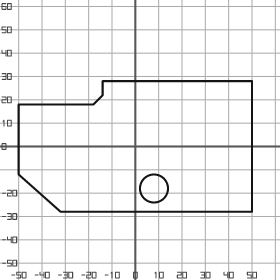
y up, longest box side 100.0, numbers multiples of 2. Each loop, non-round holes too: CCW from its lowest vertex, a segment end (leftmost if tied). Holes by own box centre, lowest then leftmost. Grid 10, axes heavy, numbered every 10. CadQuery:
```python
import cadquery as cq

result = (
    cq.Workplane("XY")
    .moveTo(-32.0, -28.0)
    .lineTo(50.0, -28.0)
    .lineTo(50.0, 28.0)
    .lineTo(-14.0, 28.0)
    .lineTo(-14.0, 22.0)
    .lineTo(-18.0, 18.0)
    .lineTo(-50.0, 18.0)
    .lineTo(-50.0, -12.0)
    .close()
    .moveTo(8.0, -18.0)
    .circle(6.0)
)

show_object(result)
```